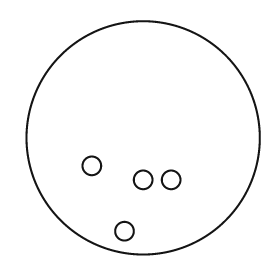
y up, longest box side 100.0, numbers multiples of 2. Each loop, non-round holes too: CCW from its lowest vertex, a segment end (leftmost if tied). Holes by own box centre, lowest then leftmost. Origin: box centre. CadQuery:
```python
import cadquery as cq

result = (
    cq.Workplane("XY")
    .moveTo(0.0, 0.0)
    .circle(50.0)
    .moveTo(-8.0, -40.0)
    .circle(4.0)
    .moveTo(0.0, -18.0)
    .circle(4.0)
    .moveTo(12.0, -18.0)
    .circle(4.0)
    .moveTo(-22.0, -12.0)
    .circle(4.0)
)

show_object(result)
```